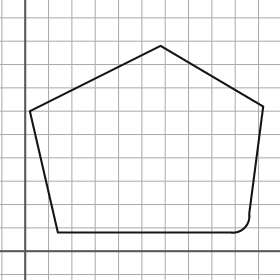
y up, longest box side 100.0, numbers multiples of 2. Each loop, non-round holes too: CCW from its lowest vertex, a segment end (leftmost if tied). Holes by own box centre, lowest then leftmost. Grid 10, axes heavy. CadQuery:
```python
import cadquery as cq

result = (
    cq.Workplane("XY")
    .moveTo(14.0, 8.0)
    .lineTo(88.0, 8.0)
    .threePointArc((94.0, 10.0), (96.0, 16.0))
    .lineTo(102.0, 62.0)
    .lineTo(58.0, 88.0)
    .lineTo(2.0, 60.0)
    .close()
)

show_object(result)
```